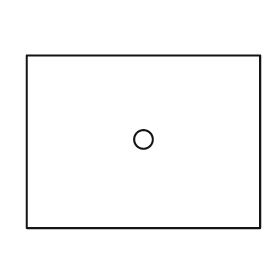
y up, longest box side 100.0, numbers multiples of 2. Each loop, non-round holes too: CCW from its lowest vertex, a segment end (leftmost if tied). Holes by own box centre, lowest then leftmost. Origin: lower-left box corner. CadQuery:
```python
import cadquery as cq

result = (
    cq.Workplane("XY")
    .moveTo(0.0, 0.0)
    .lineTo(100.0, 0.0)
    .lineTo(100.0, 74.0)
    .lineTo(0.0, 74.0)
    .close()
    .moveTo(50.0, 38.0)
    .circle(4.0)
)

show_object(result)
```